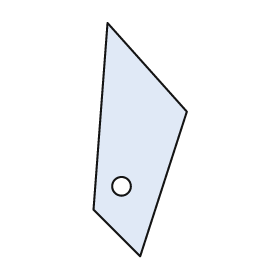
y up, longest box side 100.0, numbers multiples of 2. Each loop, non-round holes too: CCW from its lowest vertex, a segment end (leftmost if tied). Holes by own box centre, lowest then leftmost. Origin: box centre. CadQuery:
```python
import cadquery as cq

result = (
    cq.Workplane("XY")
    .moveTo(0.0, -50.0)
    .lineTo(20.0, 12.0)
    .lineTo(-14.0, 50.0)
    .lineTo(-20.0, -30.0)
    .close()
    .moveTo(-8.0, -20.0)
    .circle(4.0)
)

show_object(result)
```